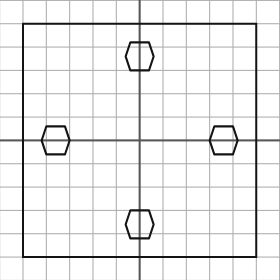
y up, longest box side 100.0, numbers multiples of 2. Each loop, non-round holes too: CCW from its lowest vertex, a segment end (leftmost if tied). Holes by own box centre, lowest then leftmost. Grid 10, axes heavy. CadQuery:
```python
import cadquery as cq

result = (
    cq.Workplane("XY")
    .moveTo(-50.0, -50.0)
    .lineTo(50.0, -50.0)
    .lineTo(50.0, 50.0)
    .lineTo(-50.0, 50.0)
    .close()
    .moveTo(-4.0, -42.0)
    .lineTo(4.0, -42.0)
    .lineTo(6.0, -36.0)
    .lineTo(4.0, -30.0)
    .lineTo(-4.0, -30.0)
    .lineTo(-6.0, -36.0)
    .close()
    .moveTo(-40.0, -6.0)
    .lineTo(-32.0, -6.0)
    .lineTo(-30.0, 0.0)
    .lineTo(-32.0, 6.0)
    .lineTo(-40.0, 6.0)
    .lineTo(-42.0, 0.0)
    .close()
    .moveTo(32.0, -6.0)
    .lineTo(40.0, -6.0)
    .lineTo(42.0, 0.0)
    .lineTo(40.0, 6.0)
    .lineTo(32.0, 6.0)
    .lineTo(30.0, 0.0)
    .close()
    .moveTo(-4.0, 30.0)
    .lineTo(4.0, 30.0)
    .lineTo(6.0, 36.0)
    .lineTo(4.0, 42.0)
    .lineTo(-4.0, 42.0)
    .lineTo(-6.0, 36.0)
    .close()
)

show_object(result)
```